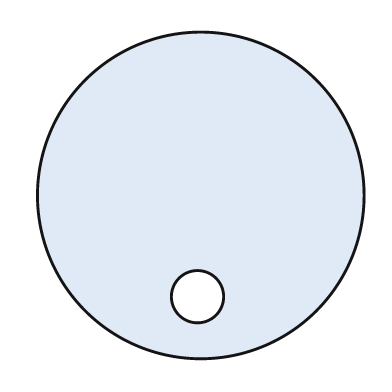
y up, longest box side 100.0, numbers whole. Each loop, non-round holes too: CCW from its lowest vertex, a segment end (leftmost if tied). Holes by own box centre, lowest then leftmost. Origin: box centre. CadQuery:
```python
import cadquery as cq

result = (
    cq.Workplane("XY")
    .moveTo(0.0, 0.0)
    .circle(50.0)
    .moveTo(-1.0, -31.0)
    .circle(8.0)
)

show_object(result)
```